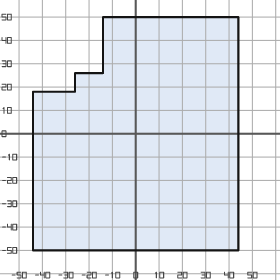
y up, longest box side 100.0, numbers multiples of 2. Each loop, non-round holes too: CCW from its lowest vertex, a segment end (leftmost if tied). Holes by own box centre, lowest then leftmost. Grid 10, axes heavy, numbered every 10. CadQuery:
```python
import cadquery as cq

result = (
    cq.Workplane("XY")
    .moveTo(-44.0, -50.0)
    .lineTo(44.0, -50.0)
    .lineTo(44.0, 50.0)
    .lineTo(-14.0, 50.0)
    .lineTo(-14.0, 26.0)
    .lineTo(-26.0, 26.0)
    .lineTo(-26.0, 18.0)
    .lineTo(-44.0, 18.0)
    .close()
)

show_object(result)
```